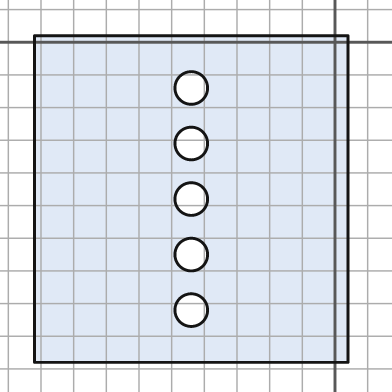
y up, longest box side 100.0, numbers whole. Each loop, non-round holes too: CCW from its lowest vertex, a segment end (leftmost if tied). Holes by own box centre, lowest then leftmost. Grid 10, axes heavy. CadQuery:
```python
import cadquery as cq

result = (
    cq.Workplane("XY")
    .moveTo(-92.0, -98.0)
    .lineTo(4.0, -98.0)
    .lineTo(4.0, 2.0)
    .lineTo(-92.0, 2.0)
    .close()
    .moveTo(-44.0, -82.0)
    .circle(5.0)
    .moveTo(-44.0, -65.0)
    .circle(5.0)
    .moveTo(-44.0, -48.0)
    .circle(5.0)
    .moveTo(-44.0, -31.0)
    .circle(5.0)
    .moveTo(-44.0, -14.0)
    .circle(5.0)
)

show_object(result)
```